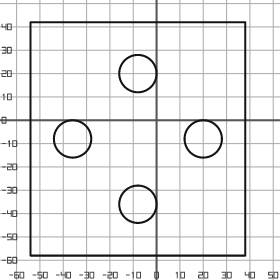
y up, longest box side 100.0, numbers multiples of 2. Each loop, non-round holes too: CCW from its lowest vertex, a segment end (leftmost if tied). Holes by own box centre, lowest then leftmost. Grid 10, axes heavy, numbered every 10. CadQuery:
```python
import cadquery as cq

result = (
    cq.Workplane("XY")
    .moveTo(-54.0, -58.0)
    .lineTo(38.0, -58.0)
    .lineTo(38.0, 42.0)
    .lineTo(-54.0, 42.0)
    .close()
    .moveTo(-8.0, -36.0)
    .circle(8.0)
    .moveTo(-36.0, -8.0)
    .circle(8.0)
    .moveTo(20.0, -8.0)
    .circle(8.0)
    .moveTo(-8.0, 20.0)
    .circle(8.0)
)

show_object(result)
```